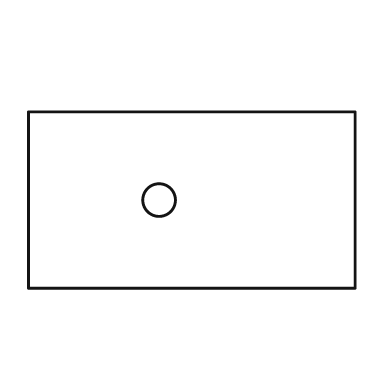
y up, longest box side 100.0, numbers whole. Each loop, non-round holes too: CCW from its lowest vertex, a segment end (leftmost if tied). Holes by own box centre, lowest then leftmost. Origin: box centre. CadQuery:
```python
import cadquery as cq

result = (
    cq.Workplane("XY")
    .moveTo(-50.0, -27.0)
    .lineTo(50.0, -27.0)
    .lineTo(50.0, 27.0)
    .lineTo(-50.0, 27.0)
    .close()
    .moveTo(-10.0, 0.0)
    .circle(5.0)
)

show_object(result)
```